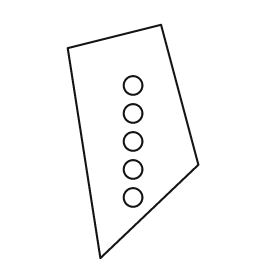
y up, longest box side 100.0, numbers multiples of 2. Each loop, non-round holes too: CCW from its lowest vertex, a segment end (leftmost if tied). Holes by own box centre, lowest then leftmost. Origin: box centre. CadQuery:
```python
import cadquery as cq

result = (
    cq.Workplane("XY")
    .moveTo(-14.0, -50.0)
    .lineTo(28.0, -10.0)
    .lineTo(12.0, 50.0)
    .lineTo(-28.0, 40.0)
    .close()
    .moveTo(0.0, -24.0)
    .circle(4.0)
    .moveTo(0.0, -12.0)
    .circle(4.0)
    .moveTo(0.0, 0.0)
    .circle(4.0)
    .moveTo(0.0, 12.0)
    .circle(4.0)
    .moveTo(0.0, 24.0)
    .circle(4.0)
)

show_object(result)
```